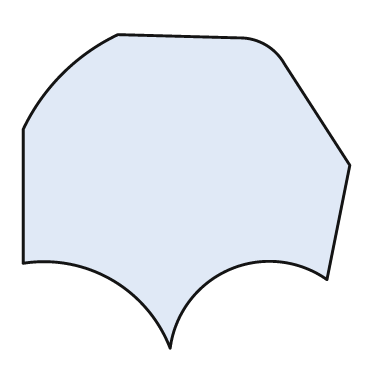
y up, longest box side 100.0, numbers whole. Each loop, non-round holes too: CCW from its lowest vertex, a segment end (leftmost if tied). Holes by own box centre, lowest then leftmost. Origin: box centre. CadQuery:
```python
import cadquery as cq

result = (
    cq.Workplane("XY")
    .moveTo(-5.0, -48.0)
    .threePointArc((13.0, -24.0), (43.0, -27.0))
    .lineTo(50.0, 8.0)
    .lineTo(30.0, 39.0)
    .threePointArc((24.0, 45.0), (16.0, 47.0))
    .lineTo(-21.0, 48.0)
    .threePointArc((-38.0, 36.0), (-50.0, 19.0))
    .lineTo(-50.0, -22.0)
    .threePointArc((-23.0, -27.0), (-5.0, -48.0))
    .close()
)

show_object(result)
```